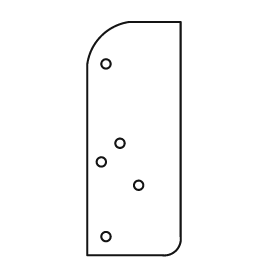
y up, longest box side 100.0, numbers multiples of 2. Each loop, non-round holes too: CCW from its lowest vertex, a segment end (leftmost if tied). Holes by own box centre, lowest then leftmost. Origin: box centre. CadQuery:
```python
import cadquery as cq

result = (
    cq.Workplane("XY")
    .moveTo(-20.0, -50.0)
    .lineTo(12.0, -50.0)
    .threePointArc((18.0, -48.0), (20.0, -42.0))
    .lineTo(20.0, 50.0)
    .lineTo(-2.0, 50.0)
    .threePointArc((-14.0, 44.0), (-20.0, 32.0))
    .close()
    .moveTo(-12.0, -42.0)
    .circle(2.0)
    .moveTo(2.0, -20.0)
    .circle(2.0)
    .moveTo(-14.0, -10.0)
    .circle(2.0)
    .moveTo(-6.0, -2.0)
    .circle(2.0)
    .moveTo(-12.0, 32.0)
    .circle(2.0)
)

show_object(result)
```